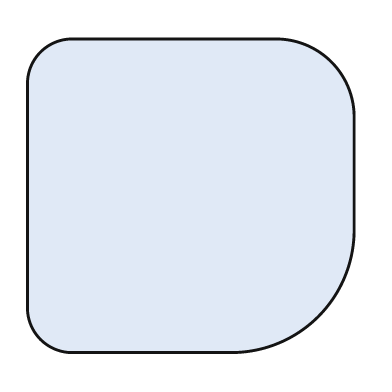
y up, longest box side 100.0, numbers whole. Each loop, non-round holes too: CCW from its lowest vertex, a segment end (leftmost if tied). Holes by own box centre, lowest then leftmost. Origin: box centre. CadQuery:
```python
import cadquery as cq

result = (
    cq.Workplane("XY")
    .moveTo(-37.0, -48.0)
    .lineTo(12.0, -48.0)
    .threePointArc((39.0, -37.0), (50.0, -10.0))
    .lineTo(50.0, 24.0)
    .threePointArc((43.0, 41.0), (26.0, 48.0))
    .lineTo(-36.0, 48.0)
    .threePointArc((-46.0, 44.0), (-50.0, 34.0))
    .lineTo(-50.0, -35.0)
    .threePointArc((-46.0, -44.0), (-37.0, -48.0))
    .close()
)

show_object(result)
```